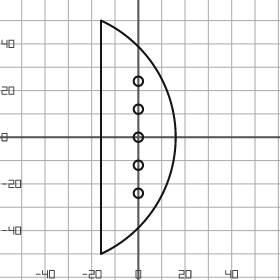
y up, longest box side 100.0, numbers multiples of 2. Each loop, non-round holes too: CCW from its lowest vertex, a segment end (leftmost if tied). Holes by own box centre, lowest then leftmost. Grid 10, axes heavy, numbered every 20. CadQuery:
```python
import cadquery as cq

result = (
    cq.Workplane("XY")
    .moveTo(-16.0, -50.0)
    .threePointArc((16.0, 0.0), (-16.0, 50.0))
    .close()
    .moveTo(0.0, -24.0)
    .circle(2.0)
    .moveTo(0.0, -12.0)
    .circle(2.0)
    .moveTo(0.0, 0.0)
    .circle(2.0)
    .moveTo(0.0, 12.0)
    .circle(2.0)
    .moveTo(0.0, 24.0)
    .circle(2.0)
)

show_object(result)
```